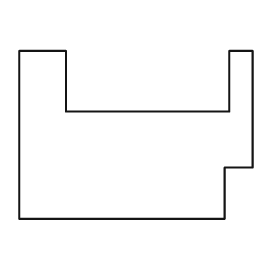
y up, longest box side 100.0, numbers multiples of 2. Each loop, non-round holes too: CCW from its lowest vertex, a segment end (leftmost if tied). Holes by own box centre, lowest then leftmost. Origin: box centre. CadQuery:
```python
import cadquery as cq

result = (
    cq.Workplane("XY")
    .moveTo(-50.0, -36.0)
    .lineTo(38.0, -36.0)
    .lineTo(38.0, -14.0)
    .lineTo(50.0, -14.0)
    .lineTo(50.0, 36.0)
    .lineTo(40.0, 36.0)
    .lineTo(40.0, 10.0)
    .lineTo(-30.0, 10.0)
    .lineTo(-30.0, 36.0)
    .lineTo(-50.0, 36.0)
    .close()
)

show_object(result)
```